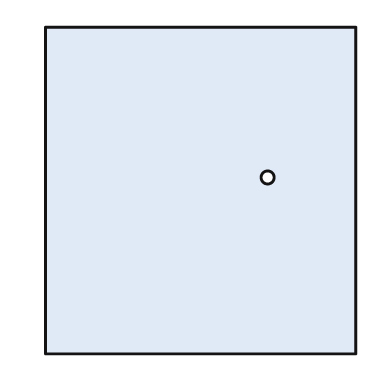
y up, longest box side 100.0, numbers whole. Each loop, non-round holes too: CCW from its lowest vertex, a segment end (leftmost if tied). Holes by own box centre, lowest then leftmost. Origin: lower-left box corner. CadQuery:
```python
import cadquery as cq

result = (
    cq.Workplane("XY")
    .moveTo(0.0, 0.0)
    .lineTo(95.0, 0.0)
    .lineTo(95.0, 100.0)
    .lineTo(0.0, 100.0)
    .close()
    .moveTo(68.0, 54.0)
    .circle(2.0)
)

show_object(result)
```